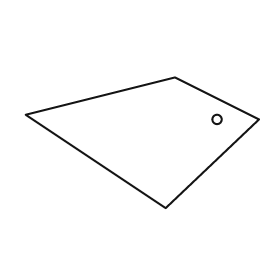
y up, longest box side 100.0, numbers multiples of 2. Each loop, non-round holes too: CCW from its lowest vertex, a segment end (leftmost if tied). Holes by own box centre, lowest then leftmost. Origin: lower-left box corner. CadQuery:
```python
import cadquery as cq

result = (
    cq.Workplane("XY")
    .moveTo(60.0, 0.0)
    .lineTo(100.0, 38.0)
    .lineTo(64.0, 56.0)
    .lineTo(0.0, 40.0)
    .close()
    .moveTo(82.0, 38.0)
    .circle(2.0)
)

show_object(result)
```